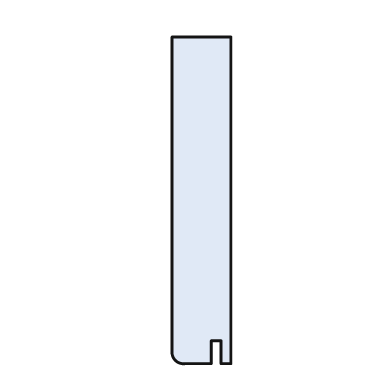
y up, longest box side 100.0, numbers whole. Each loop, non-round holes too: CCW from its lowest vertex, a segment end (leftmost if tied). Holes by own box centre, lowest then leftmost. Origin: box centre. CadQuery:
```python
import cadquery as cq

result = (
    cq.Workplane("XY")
    .moveTo(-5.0, -50.0)
    .lineTo(3.0, -50.0)
    .lineTo(3.0, -43.0)
    .lineTo(6.0, -43.0)
    .lineTo(6.0, -50.0)
    .lineTo(9.0, -50.0)
    .lineTo(9.0, 50.0)
    .lineTo(-9.0, 50.0)
    .lineTo(-9.0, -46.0)
    .threePointArc((-8.0, -49.0), (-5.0, -50.0))
    .close()
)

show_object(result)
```